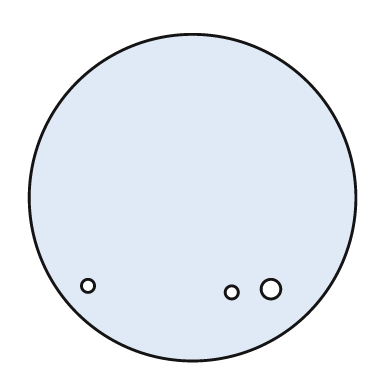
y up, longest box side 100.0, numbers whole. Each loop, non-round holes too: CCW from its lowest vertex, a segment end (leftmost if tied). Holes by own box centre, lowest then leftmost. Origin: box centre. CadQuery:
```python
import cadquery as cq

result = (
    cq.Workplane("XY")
    .moveTo(0.0, 0.0)
    .circle(50.0)
    .moveTo(12.0, -29.0)
    .circle(2.0)
    .moveTo(24.0, -28.0)
    .circle(3.0)
    .moveTo(-32.0, -27.0)
    .circle(2.0)
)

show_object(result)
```